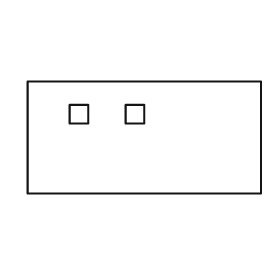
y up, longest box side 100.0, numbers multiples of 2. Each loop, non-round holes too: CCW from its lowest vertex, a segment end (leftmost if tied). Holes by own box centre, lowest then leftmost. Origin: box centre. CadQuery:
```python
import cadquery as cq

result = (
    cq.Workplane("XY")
    .moveTo(-50.0, -24.0)
    .lineTo(50.0, -24.0)
    .lineTo(50.0, 24.0)
    .lineTo(-50.0, 24.0)
    .close()
    .moveTo(-32.0, 6.0)
    .lineTo(-24.0, 6.0)
    .lineTo(-24.0, 14.0)
    .lineTo(-32.0, 14.0)
    .close()
    .moveTo(-8.0, 6.0)
    .lineTo(0.0, 6.0)
    .lineTo(0.0, 14.0)
    .lineTo(-8.0, 14.0)
    .close()
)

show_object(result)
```